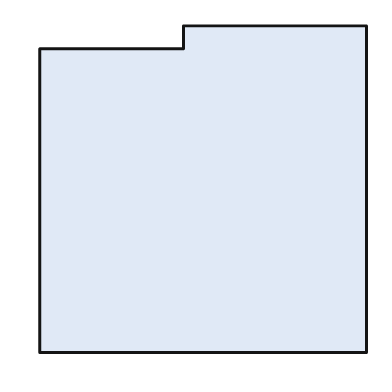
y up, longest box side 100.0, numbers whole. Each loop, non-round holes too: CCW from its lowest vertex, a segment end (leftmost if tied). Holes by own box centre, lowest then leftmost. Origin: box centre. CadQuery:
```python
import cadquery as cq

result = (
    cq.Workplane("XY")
    .moveTo(-50.0, -50.0)
    .lineTo(50.0, -50.0)
    .lineTo(50.0, 50.0)
    .lineTo(-6.0, 50.0)
    .lineTo(-6.0, 43.0)
    .lineTo(-50.0, 43.0)
    .close()
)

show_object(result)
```